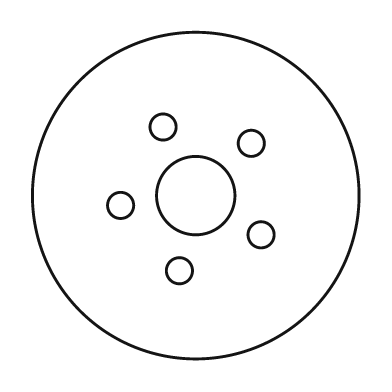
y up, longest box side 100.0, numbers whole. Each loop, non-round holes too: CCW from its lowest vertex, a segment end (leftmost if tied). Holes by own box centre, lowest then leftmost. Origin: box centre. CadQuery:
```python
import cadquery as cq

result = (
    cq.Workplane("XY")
    .moveTo(0.0, 0.0)
    .circle(50.0)
    .moveTo(-5.0, -23.0)
    .circle(4.0)
    .moveTo(20.0, -12.0)
    .circle(4.0)
    .moveTo(-23.0, -3.0)
    .circle(4.0)
    .moveTo(0.0, 0.0)
    .circle(12.0)
    .moveTo(17.0, 16.0)
    .circle(4.0)
    .moveTo(-10.0, 21.0)
    .circle(4.0)
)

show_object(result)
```